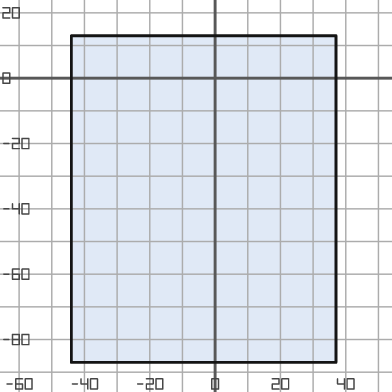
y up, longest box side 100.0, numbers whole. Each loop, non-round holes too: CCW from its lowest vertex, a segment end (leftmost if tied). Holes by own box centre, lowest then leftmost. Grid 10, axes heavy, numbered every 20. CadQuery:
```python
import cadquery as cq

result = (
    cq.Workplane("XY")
    .moveTo(-44.0, -87.0)
    .lineTo(37.0, -87.0)
    .lineTo(37.0, 13.0)
    .lineTo(-44.0, 13.0)
    .close()
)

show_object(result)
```